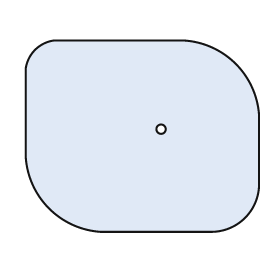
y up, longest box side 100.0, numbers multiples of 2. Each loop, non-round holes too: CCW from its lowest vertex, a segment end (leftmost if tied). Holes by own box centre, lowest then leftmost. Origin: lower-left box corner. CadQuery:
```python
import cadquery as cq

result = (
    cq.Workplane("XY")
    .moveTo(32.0, 0.0)
    .lineTo(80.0, 0.0)
    .threePointArc((94.0, 6.0), (100.0, 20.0))
    .lineTo(100.0, 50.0)
    .threePointArc((90.0, 72.0), (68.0, 82.0))
    .lineTo(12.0, 82.0)
    .threePointArc((4.0, 78.0), (0.0, 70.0))
    .lineTo(0.0, 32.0)
    .threePointArc((10.0, 10.0), (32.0, 0.0))
    .close()
    .moveTo(58.0, 44.0)
    .circle(2.0)
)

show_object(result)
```